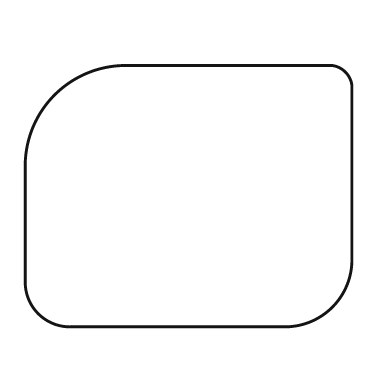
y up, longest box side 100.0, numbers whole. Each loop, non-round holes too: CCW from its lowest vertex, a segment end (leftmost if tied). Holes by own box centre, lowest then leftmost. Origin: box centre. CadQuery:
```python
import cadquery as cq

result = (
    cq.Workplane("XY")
    .moveTo(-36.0, -40.0)
    .lineTo(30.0, -40.0)
    .threePointArc((44.0, -34.0), (50.0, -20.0))
    .lineTo(50.0, 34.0)
    .threePointArc((48.0, 38.0), (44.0, 40.0))
    .lineTo(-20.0, 40.0)
    .threePointArc((-41.0, 31.0), (-50.0, 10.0))
    .lineTo(-50.0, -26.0)
    .threePointArc((-46.0, -36.0), (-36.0, -40.0))
    .close()
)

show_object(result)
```